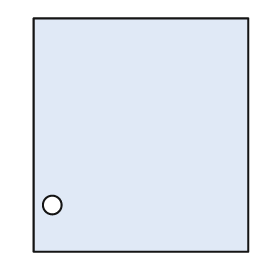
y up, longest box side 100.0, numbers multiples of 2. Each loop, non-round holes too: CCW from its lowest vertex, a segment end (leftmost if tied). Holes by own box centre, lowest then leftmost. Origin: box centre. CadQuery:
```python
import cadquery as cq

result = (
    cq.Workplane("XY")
    .moveTo(-46.0, -50.0)
    .lineTo(46.0, -50.0)
    .lineTo(46.0, 50.0)
    .lineTo(-46.0, 50.0)
    .close()
    .moveTo(-38.0, -30.0)
    .circle(4.0)
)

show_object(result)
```